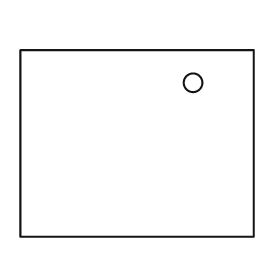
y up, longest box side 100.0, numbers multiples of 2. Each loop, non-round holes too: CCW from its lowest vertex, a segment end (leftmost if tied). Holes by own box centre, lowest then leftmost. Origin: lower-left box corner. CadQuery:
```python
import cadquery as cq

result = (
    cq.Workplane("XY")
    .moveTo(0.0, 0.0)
    .lineTo(100.0, 0.0)
    .lineTo(100.0, 80.0)
    .lineTo(0.0, 80.0)
    .close()
    .moveTo(74.0, 66.0)
    .circle(4.0)
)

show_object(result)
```